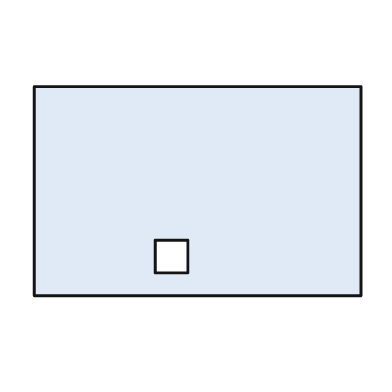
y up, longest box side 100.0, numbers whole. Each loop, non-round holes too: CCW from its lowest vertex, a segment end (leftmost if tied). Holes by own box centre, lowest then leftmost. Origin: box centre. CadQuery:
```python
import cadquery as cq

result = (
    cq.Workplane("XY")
    .moveTo(-50.0, -32.0)
    .lineTo(50.0, -32.0)
    .lineTo(50.0, 32.0)
    .lineTo(-50.0, 32.0)
    .close()
    .moveTo(-13.0, -25.0)
    .lineTo(-3.0, -25.0)
    .lineTo(-3.0, -15.0)
    .lineTo(-13.0, -15.0)
    .close()
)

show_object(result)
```